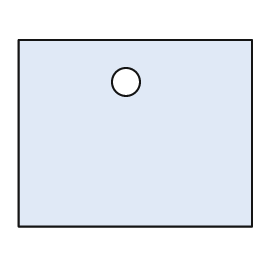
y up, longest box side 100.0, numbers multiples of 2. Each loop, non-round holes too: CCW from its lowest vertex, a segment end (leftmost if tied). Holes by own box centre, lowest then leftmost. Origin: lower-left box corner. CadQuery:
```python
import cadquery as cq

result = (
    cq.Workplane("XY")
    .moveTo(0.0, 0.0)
    .lineTo(100.0, 0.0)
    .lineTo(100.0, 80.0)
    .lineTo(0.0, 80.0)
    .close()
    .moveTo(46.0, 62.0)
    .circle(6.0)
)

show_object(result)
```